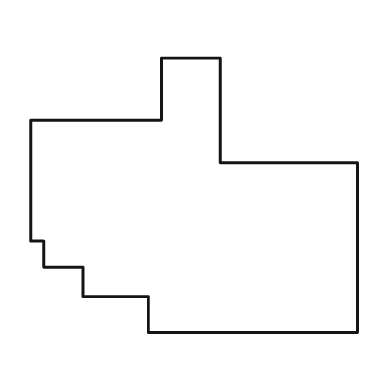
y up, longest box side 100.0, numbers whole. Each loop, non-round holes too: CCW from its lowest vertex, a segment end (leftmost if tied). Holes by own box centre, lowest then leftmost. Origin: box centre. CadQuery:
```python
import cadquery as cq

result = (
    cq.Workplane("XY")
    .moveTo(-14.0, -42.0)
    .lineTo(50.0, -42.0)
    .lineTo(50.0, 10.0)
    .lineTo(8.0, 10.0)
    .lineTo(8.0, 42.0)
    .lineTo(-10.0, 42.0)
    .lineTo(-10.0, 23.0)
    .lineTo(-50.0, 23.0)
    .lineTo(-50.0, -14.0)
    .lineTo(-46.0, -14.0)
    .lineTo(-46.0, -22.0)
    .lineTo(-34.0, -22.0)
    .lineTo(-34.0, -31.0)
    .lineTo(-14.0, -31.0)
    .close()
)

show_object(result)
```